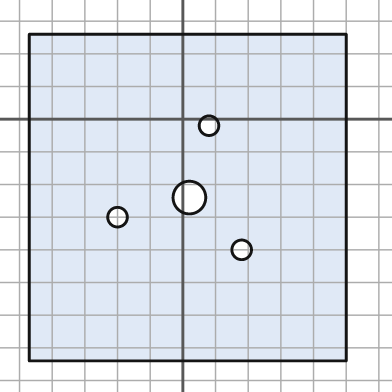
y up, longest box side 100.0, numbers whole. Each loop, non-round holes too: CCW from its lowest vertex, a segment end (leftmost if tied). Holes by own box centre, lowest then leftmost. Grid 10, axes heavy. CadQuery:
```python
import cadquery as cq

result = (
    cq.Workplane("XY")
    .moveTo(-47.0, -74.0)
    .lineTo(50.0, -74.0)
    .lineTo(50.0, 26.0)
    .lineTo(-47.0, 26.0)
    .close()
    .moveTo(18.0, -40.0)
    .circle(3.0)
    .moveTo(-20.0, -30.0)
    .circle(3.0)
    .moveTo(2.0, -24.0)
    .circle(5.0)
    .moveTo(8.0, -2.0)
    .circle(3.0)
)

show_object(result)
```